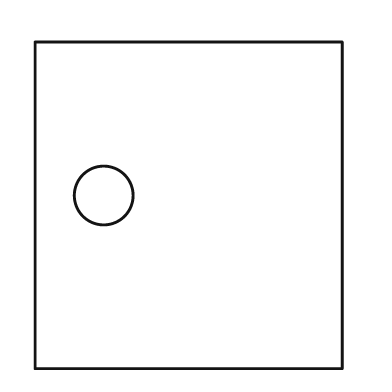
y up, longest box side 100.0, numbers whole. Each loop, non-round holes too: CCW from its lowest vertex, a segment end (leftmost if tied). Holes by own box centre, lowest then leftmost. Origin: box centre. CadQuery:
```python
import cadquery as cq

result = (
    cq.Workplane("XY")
    .moveTo(-47.0, -50.0)
    .lineTo(47.0, -50.0)
    .lineTo(47.0, 50.0)
    .lineTo(-47.0, 50.0)
    .close()
    .moveTo(-26.0, 3.0)
    .circle(9.0)
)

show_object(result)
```